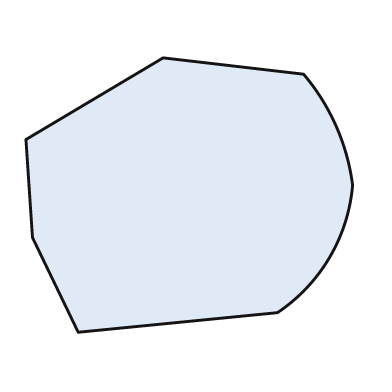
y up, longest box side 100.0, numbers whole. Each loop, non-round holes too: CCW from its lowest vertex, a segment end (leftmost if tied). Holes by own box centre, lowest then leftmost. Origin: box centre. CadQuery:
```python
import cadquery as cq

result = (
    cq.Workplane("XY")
    .moveTo(-34.0, -42.0)
    .lineTo(27.0, -36.0)
    .threePointArc((43.0, -19.0), (50.0, 3.0))
    .threePointArc((45.0, 21.0), (35.0, 37.0))
    .lineTo(-8.0, 42.0)
    .lineTo(-50.0, 17.0)
    .lineTo(-48.0, -13.0)
    .close()
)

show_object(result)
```